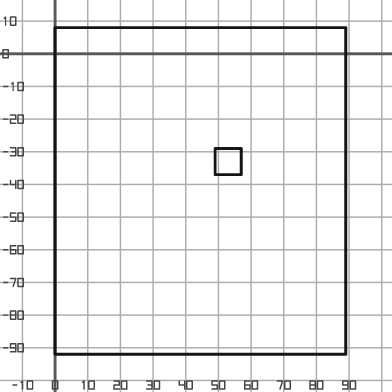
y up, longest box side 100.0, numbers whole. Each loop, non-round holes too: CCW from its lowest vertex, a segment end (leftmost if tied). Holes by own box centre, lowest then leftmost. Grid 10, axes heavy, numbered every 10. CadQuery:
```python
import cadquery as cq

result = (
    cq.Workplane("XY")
    .moveTo(0.0, -92.0)
    .lineTo(89.0, -92.0)
    .lineTo(89.0, 8.0)
    .lineTo(0.0, 8.0)
    .close()
    .moveTo(49.0, -37.0)
    .lineTo(57.0, -37.0)
    .lineTo(57.0, -29.0)
    .lineTo(49.0, -29.0)
    .close()
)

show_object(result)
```